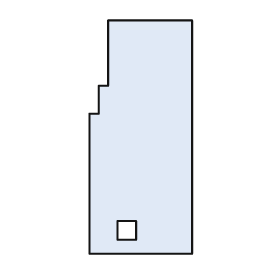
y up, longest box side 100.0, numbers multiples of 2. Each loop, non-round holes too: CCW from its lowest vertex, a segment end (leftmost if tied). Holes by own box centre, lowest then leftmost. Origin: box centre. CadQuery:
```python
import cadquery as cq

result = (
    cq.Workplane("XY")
    .moveTo(-22.0, -50.0)
    .lineTo(22.0, -50.0)
    .lineTo(22.0, 50.0)
    .lineTo(-14.0, 50.0)
    .lineTo(-14.0, 22.0)
    .lineTo(-18.0, 22.0)
    .lineTo(-18.0, 10.0)
    .lineTo(-22.0, 10.0)
    .close()
    .moveTo(-10.0, -44.0)
    .lineTo(-2.0, -44.0)
    .lineTo(-2.0, -36.0)
    .lineTo(-10.0, -36.0)
    .close()
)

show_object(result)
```